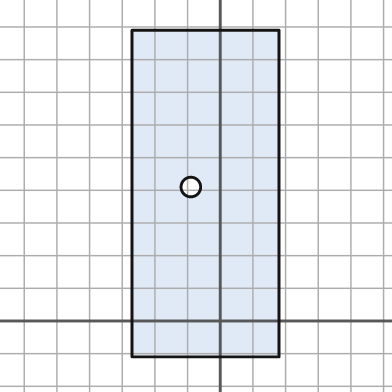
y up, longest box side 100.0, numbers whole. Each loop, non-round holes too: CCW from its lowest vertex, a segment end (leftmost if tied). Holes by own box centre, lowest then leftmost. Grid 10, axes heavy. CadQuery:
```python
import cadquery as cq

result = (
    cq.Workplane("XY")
    .moveTo(-27.0, -11.0)
    .lineTo(18.0, -11.0)
    .lineTo(18.0, 89.0)
    .lineTo(-27.0, 89.0)
    .close()
    .moveTo(-9.0, 41.0)
    .circle(3.0)
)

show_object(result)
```